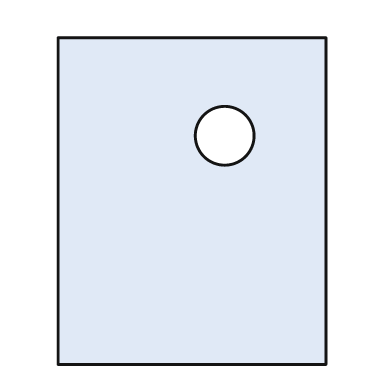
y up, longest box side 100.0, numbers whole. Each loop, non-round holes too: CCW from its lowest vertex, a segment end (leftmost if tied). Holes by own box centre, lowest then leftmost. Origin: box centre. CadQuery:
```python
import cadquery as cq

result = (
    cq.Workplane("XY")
    .moveTo(-41.0, -50.0)
    .lineTo(41.0, -50.0)
    .lineTo(41.0, 50.0)
    .lineTo(-41.0, 50.0)
    .close()
    .moveTo(10.0, 20.0)
    .circle(9.0)
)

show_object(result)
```